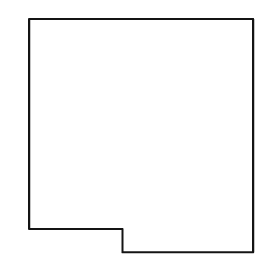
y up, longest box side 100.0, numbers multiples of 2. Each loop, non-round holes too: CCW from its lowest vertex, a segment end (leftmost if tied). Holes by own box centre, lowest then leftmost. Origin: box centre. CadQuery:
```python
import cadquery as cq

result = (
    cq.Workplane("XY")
    .moveTo(-8.0, -50.0)
    .lineTo(48.0, -50.0)
    .lineTo(48.0, 50.0)
    .lineTo(-48.0, 50.0)
    .lineTo(-48.0, -40.0)
    .lineTo(-8.0, -40.0)
    .close()
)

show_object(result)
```